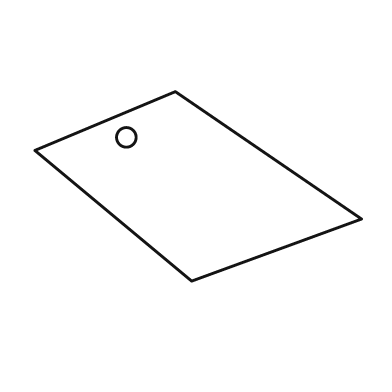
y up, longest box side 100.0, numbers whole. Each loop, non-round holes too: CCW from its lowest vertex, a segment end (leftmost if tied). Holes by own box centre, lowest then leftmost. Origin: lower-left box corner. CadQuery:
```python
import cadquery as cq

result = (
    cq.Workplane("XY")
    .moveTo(48.0, 0.0)
    .lineTo(100.0, 19.0)
    .lineTo(43.0, 58.0)
    .lineTo(0.0, 40.0)
    .close()
    .moveTo(28.0, 44.0)
    .circle(3.0)
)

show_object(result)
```